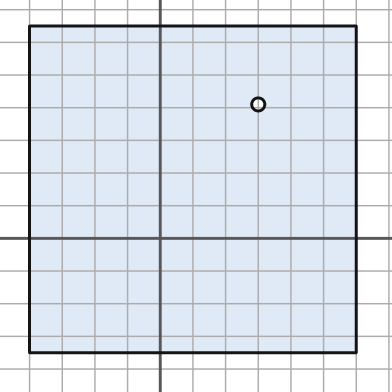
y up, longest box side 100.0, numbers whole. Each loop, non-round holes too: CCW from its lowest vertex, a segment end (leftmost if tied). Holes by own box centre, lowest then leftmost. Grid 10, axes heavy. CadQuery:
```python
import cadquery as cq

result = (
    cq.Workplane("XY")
    .moveTo(-40.0, -35.0)
    .lineTo(60.0, -35.0)
    .lineTo(60.0, 65.0)
    .lineTo(-40.0, 65.0)
    .close()
    .moveTo(30.0, 41.0)
    .circle(2.0)
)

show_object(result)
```